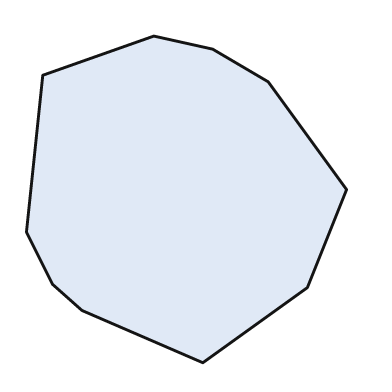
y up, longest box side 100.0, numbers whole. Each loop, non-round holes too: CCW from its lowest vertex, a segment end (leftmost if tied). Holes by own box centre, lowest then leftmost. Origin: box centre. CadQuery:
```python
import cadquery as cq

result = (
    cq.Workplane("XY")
    .moveTo(5.0, -50.0)
    .lineTo(37.0, -27.0)
    .lineTo(49.0, 3.0)
    .lineTo(25.0, 36.0)
    .lineTo(8.0, 46.0)
    .lineTo(-10.0, 50.0)
    .lineTo(-44.0, 38.0)
    .lineTo(-49.0, -10.0)
    .lineTo(-41.0, -26.0)
    .lineTo(-32.0, -34.0)
    .close()
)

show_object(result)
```